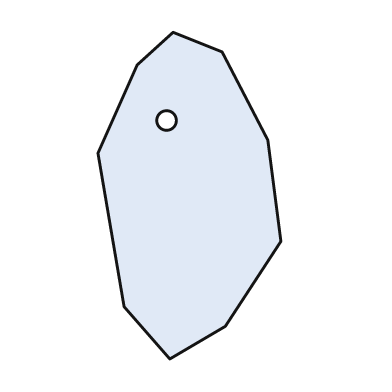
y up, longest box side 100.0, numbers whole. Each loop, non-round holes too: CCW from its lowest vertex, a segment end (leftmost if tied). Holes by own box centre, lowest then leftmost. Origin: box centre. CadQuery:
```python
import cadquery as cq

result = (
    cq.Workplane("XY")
    .moveTo(-6.0, -50.0)
    .lineTo(11.0, -40.0)
    .lineTo(28.0, -14.0)
    .lineTo(24.0, 17.0)
    .lineTo(10.0, 44.0)
    .lineTo(-5.0, 50.0)
    .lineTo(-16.0, 40.0)
    .lineTo(-28.0, 13.0)
    .lineTo(-20.0, -34.0)
    .close()
    .moveTo(-7.0, 23.0)
    .circle(3.0)
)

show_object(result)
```